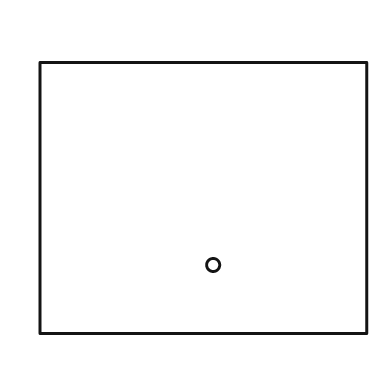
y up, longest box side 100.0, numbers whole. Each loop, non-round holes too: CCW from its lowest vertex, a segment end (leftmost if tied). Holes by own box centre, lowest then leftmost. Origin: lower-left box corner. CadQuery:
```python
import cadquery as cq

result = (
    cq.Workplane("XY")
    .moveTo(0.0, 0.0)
    .lineTo(100.0, 0.0)
    .lineTo(100.0, 83.0)
    .lineTo(0.0, 83.0)
    .close()
    .moveTo(53.0, 21.0)
    .circle(2.0)
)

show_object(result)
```